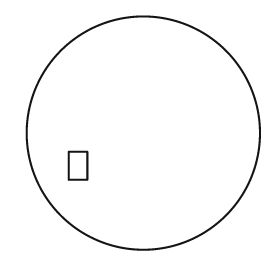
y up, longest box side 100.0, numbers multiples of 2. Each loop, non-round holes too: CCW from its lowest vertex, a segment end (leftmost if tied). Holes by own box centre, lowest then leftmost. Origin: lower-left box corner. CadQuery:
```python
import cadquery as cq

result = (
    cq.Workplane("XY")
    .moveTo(50.0, 50.0)
    .circle(50.0)
    .moveTo(18.0, 30.0)
    .lineTo(26.0, 30.0)
    .lineTo(26.0, 42.0)
    .lineTo(18.0, 42.0)
    .close()
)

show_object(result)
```